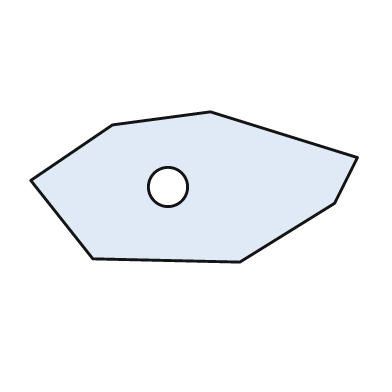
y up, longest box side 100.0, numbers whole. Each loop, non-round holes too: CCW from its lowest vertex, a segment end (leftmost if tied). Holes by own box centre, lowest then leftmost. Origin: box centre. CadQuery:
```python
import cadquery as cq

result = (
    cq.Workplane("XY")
    .moveTo(14.0, -23.0)
    .lineTo(43.0, -5.0)
    .lineTo(50.0, 9.0)
    .lineTo(5.0, 23.0)
    .lineTo(-25.0, 19.0)
    .lineTo(-50.0, 2.0)
    .lineTo(-31.0, -22.0)
    .close()
    .moveTo(-8.0, 0.0)
    .circle(6.0)
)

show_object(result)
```